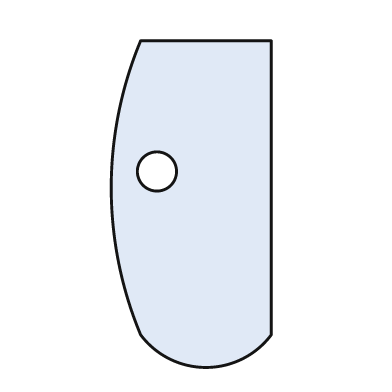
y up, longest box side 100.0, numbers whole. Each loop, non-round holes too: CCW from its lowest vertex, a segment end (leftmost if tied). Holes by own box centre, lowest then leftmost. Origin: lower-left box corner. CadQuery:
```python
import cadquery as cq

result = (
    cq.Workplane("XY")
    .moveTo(9.0, 10.0)
    .threePointArc((29.0, 0.0), (49.0, 10.0))
    .lineTo(49.0, 100.0)
    .lineTo(9.0, 100.0)
    .threePointArc((0.0, 55.0), (9.0, 10.0))
    .close()
    .moveTo(14.0, 60.0)
    .circle(6.0)
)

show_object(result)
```